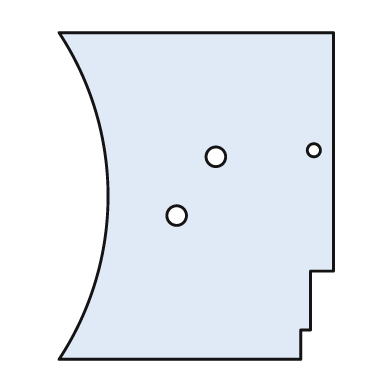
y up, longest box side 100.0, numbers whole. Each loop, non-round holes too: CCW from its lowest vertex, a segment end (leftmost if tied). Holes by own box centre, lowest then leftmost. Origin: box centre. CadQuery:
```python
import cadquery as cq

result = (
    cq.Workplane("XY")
    .moveTo(-42.0, -50.0)
    .lineTo(32.0, -50.0)
    .lineTo(32.0, -41.0)
    .lineTo(35.0, -41.0)
    .lineTo(35.0, -23.0)
    .lineTo(42.0, -23.0)
    .lineTo(42.0, 50.0)
    .lineTo(-42.0, 50.0)
    .threePointArc((-27.0, 0.0), (-42.0, -50.0))
    .close()
    .moveTo(-6.0, -6.0)
    .circle(3.0)
    .moveTo(6.0, 12.0)
    .circle(3.0)
    .moveTo(36.0, 14.0)
    .circle(2.0)
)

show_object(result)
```